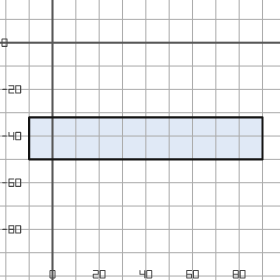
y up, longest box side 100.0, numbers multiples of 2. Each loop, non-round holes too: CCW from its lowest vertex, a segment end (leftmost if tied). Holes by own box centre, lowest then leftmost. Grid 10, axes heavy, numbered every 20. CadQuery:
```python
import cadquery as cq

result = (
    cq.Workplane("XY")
    .moveTo(-10.0, -50.0)
    .lineTo(90.0, -50.0)
    .lineTo(90.0, -32.0)
    .lineTo(-10.0, -32.0)
    .close()
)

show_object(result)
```